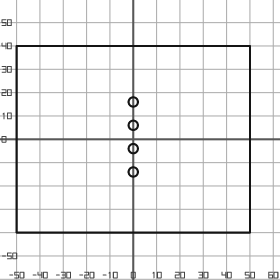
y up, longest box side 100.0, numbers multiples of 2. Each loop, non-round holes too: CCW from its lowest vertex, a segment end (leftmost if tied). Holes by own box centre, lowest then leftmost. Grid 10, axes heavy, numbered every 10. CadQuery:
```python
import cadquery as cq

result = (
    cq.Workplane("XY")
    .moveTo(-50.0, -40.0)
    .lineTo(50.0, -40.0)
    .lineTo(50.0, 40.0)
    .lineTo(-50.0, 40.0)
    .close()
    .moveTo(0.0, -14.0)
    .circle(2.0)
    .moveTo(0.0, -4.0)
    .circle(2.0)
    .moveTo(0.0, 6.0)
    .circle(2.0)
    .moveTo(0.0, 16.0)
    .circle(2.0)
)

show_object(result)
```